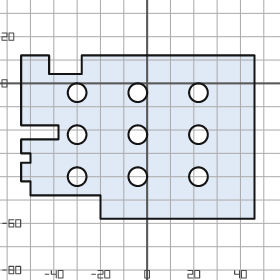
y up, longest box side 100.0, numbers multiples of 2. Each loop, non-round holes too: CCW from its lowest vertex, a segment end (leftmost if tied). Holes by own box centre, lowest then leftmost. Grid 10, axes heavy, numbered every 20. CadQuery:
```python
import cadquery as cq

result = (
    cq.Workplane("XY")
    .moveTo(-20.0, -58.0)
    .lineTo(46.0, -58.0)
    .lineTo(46.0, 12.0)
    .lineTo(-28.0, 12.0)
    .lineTo(-28.0, 4.0)
    .lineTo(-42.0, 4.0)
    .lineTo(-42.0, 12.0)
    .lineTo(-54.0, 12.0)
    .lineTo(-54.0, -18.0)
    .lineTo(-38.0, -18.0)
    .lineTo(-38.0, -24.0)
    .lineTo(-54.0, -24.0)
    .lineTo(-54.0, -30.0)
    .lineTo(-50.0, -30.0)
    .lineTo(-50.0, -34.0)
    .lineTo(-54.0, -34.0)
    .lineTo(-54.0, -42.0)
    .lineTo(-50.0, -42.0)
    .lineTo(-50.0, -48.0)
    .lineTo(-20.0, -48.0)
    .close()
    .moveTo(-30.0, -40.0)
    .circle(4.0)
    .moveTo(-4.0, -40.0)
    .circle(4.0)
    .moveTo(22.0, -40.0)
    .circle(4.0)
    .moveTo(-30.0, -22.0)
    .circle(4.0)
    .moveTo(-4.0, -22.0)
    .circle(4.0)
    .moveTo(22.0, -22.0)
    .circle(4.0)
    .moveTo(-30.0, -4.0)
    .circle(4.0)
    .moveTo(-4.0, -4.0)
    .circle(4.0)
    .moveTo(22.0, -4.0)
    .circle(4.0)
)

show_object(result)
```